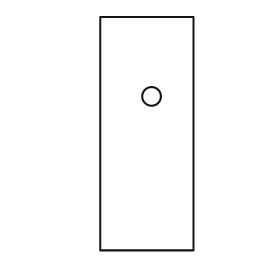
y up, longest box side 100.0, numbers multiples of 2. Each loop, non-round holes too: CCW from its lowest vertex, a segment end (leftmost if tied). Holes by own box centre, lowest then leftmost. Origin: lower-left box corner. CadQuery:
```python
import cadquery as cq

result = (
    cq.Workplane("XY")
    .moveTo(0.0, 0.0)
    .lineTo(40.0, 0.0)
    .lineTo(40.0, 100.0)
    .lineTo(0.0, 100.0)
    .close()
    .moveTo(22.0, 66.0)
    .circle(4.0)
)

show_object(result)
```